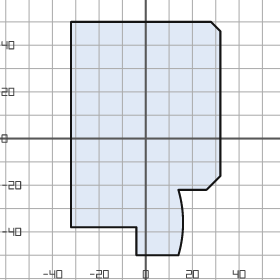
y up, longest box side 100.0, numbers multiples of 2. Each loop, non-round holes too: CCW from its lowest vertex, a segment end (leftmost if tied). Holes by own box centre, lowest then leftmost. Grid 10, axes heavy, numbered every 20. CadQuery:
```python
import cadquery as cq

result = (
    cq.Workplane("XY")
    .moveTo(-4.0, -50.0)
    .lineTo(14.0, -50.0)
    .threePointArc((16.0, -36.0), (14.0, -22.0))
    .lineTo(26.0, -22.0)
    .lineTo(32.0, -16.0)
    .lineTo(32.0, 46.0)
    .lineTo(28.0, 50.0)
    .lineTo(-32.0, 50.0)
    .lineTo(-32.0, -38.0)
    .lineTo(-4.0, -38.0)
    .close()
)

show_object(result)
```